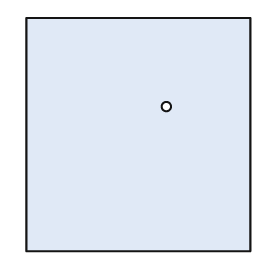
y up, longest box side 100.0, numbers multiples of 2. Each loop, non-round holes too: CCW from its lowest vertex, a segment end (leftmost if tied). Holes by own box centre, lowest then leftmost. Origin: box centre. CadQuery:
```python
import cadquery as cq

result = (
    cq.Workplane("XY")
    .moveTo(-48.0, -50.0)
    .lineTo(48.0, -50.0)
    .lineTo(48.0, 50.0)
    .lineTo(-48.0, 50.0)
    .close()
    .moveTo(12.0, 12.0)
    .circle(2.0)
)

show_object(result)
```